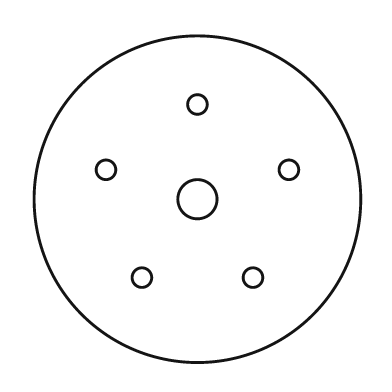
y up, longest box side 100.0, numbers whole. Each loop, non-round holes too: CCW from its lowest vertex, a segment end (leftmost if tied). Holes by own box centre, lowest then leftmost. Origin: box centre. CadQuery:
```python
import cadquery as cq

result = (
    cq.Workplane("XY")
    .moveTo(0.0, 0.0)
    .circle(50.0)
    .moveTo(-17.0, -24.0)
    .circle(3.0)
    .moveTo(17.0, -24.0)
    .circle(3.0)
    .moveTo(0.0, 0.0)
    .circle(6.0)
    .moveTo(-28.0, 9.0)
    .circle(3.0)
    .moveTo(28.0, 9.0)
    .circle(3.0)
    .moveTo(0.0, 29.0)
    .circle(3.0)
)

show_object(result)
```